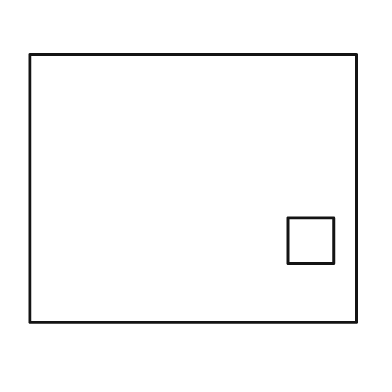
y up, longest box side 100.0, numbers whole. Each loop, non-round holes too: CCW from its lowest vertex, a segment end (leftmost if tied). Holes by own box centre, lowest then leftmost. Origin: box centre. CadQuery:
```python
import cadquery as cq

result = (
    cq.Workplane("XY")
    .moveTo(-50.0, -41.0)
    .lineTo(50.0, -41.0)
    .lineTo(50.0, 41.0)
    .lineTo(-50.0, 41.0)
    .close()
    .moveTo(29.0, -23.0)
    .lineTo(43.0, -23.0)
    .lineTo(43.0, -9.0)
    .lineTo(29.0, -9.0)
    .close()
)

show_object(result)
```